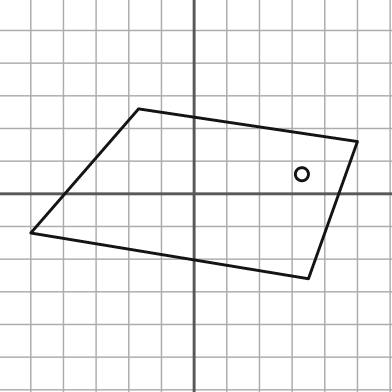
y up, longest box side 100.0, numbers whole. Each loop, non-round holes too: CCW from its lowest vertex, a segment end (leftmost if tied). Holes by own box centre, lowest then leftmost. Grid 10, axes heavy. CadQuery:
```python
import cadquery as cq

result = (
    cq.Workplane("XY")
    .moveTo(35.0, -26.0)
    .lineTo(50.0, 16.0)
    .lineTo(-17.0, 26.0)
    .lineTo(-50.0, -12.0)
    .close()
    .moveTo(33.0, 6.0)
    .circle(2.0)
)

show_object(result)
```